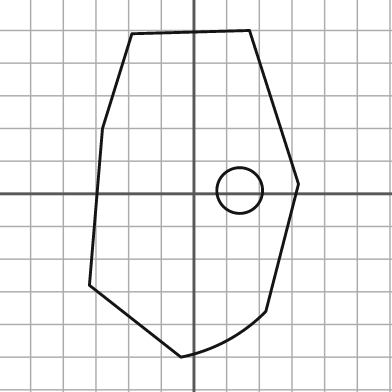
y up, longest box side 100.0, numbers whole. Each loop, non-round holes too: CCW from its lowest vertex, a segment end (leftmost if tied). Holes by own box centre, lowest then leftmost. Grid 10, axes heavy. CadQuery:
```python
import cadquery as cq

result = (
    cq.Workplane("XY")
    .moveTo(-4.0, -50.0)
    .threePointArc((10.0, -45.0), (22.0, -36.0))
    .lineTo(32.0, 3.0)
    .lineTo(17.0, 50.0)
    .lineTo(-19.0, 49.0)
    .lineTo(-28.0, 20.0)
    .lineTo(-32.0, -28.0)
    .close()
    .moveTo(14.0, 1.0)
    .circle(7.0)
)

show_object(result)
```